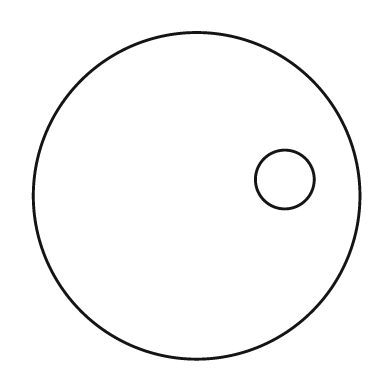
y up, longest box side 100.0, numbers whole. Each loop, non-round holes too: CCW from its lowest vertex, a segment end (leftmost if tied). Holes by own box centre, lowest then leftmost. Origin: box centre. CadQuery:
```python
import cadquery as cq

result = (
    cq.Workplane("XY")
    .moveTo(0.0, 0.0)
    .circle(50.0)
    .moveTo(27.0, 5.0)
    .circle(9.0)
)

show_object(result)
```